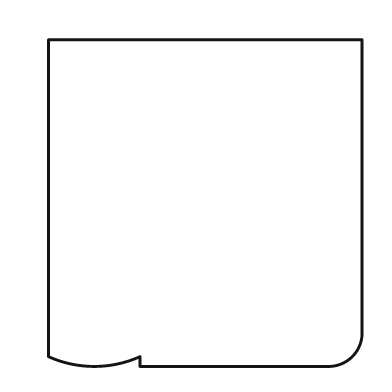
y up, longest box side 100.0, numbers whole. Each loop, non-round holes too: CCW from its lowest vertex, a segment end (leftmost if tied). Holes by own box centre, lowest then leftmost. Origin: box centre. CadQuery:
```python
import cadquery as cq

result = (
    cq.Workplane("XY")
    .moveTo(-20.0, -50.0)
    .lineTo(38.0, -50.0)
    .threePointArc((45.0, -47.0), (48.0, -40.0))
    .lineTo(48.0, 50.0)
    .lineTo(-48.0, 50.0)
    .lineTo(-48.0, -47.0)
    .threePointArc((-34.0, -50.0), (-20.0, -47.0))
    .close()
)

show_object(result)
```